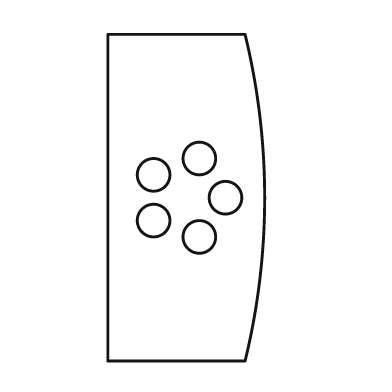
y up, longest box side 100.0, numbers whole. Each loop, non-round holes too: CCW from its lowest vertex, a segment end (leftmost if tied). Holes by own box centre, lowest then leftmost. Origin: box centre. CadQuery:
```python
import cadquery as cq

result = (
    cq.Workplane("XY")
    .moveTo(-24.0, -50.0)
    .lineTo(18.0, -50.0)
    .threePointArc((24.0, 0.0), (18.0, 50.0))
    .lineTo(-24.0, 50.0)
    .close()
    .moveTo(4.0, -12.0)
    .circle(5.0)
    .moveTo(-10.0, -7.0)
    .circle(5.0)
    .moveTo(12.0, 0.0)
    .circle(5.0)
    .moveTo(-10.0, 7.0)
    .circle(5.0)
    .moveTo(4.0, 12.0)
    .circle(5.0)
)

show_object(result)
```